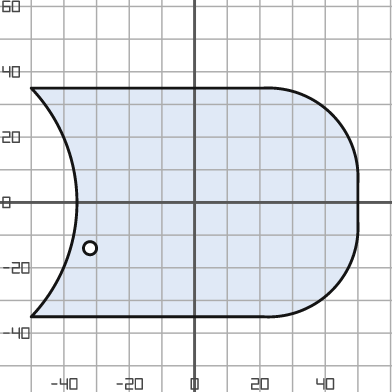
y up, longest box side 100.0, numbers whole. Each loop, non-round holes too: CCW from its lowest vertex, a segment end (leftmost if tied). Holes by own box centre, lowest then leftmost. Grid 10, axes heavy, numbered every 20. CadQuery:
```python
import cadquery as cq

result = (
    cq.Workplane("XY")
    .moveTo(-50.0, -35.0)
    .lineTo(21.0, -35.0)
    .threePointArc((42.0, -27.0), (50.0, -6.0))
    .lineTo(50.0, 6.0)
    .threePointArc((42.0, 27.0), (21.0, 35.0))
    .lineTo(-50.0, 35.0)
    .threePointArc((-36.0, 0.0), (-50.0, -35.0))
    .close()
    .moveTo(-32.0, -14.0)
    .circle(2.0)
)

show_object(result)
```